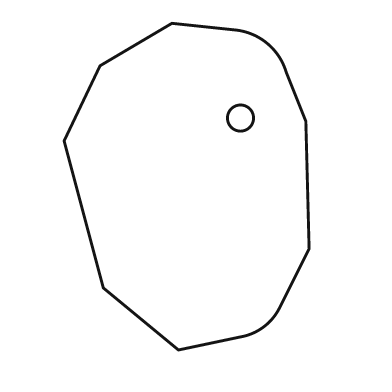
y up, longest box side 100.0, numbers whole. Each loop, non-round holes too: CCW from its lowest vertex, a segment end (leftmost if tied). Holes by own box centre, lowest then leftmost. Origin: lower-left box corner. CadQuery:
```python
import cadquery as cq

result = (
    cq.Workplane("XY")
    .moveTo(35.0, 0.0)
    .lineTo(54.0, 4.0)
    .threePointArc((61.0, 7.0), (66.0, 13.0))
    .lineTo(75.0, 31.0)
    .lineTo(74.0, 70.0)
    .lineTo(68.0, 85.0)
    .threePointArc((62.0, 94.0), (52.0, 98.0))
    .lineTo(33.0, 100.0)
    .lineTo(11.0, 87.0)
    .lineTo(0.0, 64.0)
    .lineTo(12.0, 19.0)
    .close()
    .moveTo(54.0, 71.0)
    .circle(4.0)
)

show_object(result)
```